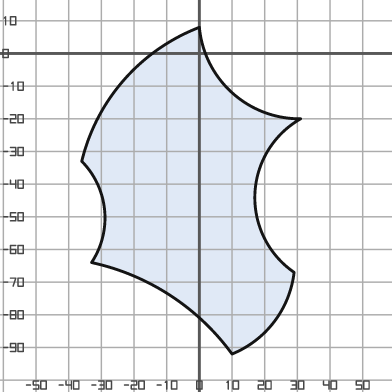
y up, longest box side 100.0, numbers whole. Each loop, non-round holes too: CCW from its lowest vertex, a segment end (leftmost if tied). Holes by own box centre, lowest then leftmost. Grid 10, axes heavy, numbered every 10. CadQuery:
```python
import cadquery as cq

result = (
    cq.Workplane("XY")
    .moveTo(10.0, -92.0)
    .threePointArc((23.0, -82.0), (29.0, -67.0))
    .threePointArc((17.0, -43.0), (31.0, -20.0))
    .threePointArc((10.0, -12.0), (0.0, 8.0))
    .threePointArc((-23.0, -8.0), (-36.0, -33.0))
    .threePointArc((-29.0, -48.0), (-33.0, -64.0))
    .threePointArc((-9.0, -74.0), (10.0, -92.0))
    .close()
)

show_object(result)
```